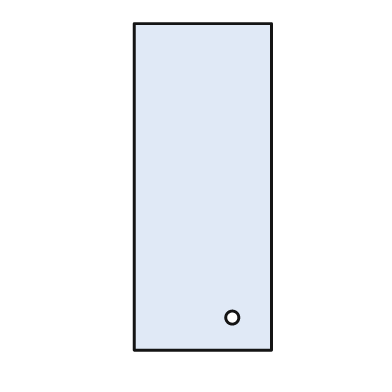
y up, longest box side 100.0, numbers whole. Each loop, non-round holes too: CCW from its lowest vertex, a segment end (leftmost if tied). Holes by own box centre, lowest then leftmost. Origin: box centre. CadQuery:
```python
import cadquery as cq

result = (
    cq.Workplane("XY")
    .moveTo(-21.0, -50.0)
    .lineTo(21.0, -50.0)
    .lineTo(21.0, 50.0)
    .lineTo(-21.0, 50.0)
    .close()
    .moveTo(9.0, -40.0)
    .circle(2.0)
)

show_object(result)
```